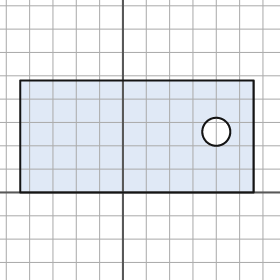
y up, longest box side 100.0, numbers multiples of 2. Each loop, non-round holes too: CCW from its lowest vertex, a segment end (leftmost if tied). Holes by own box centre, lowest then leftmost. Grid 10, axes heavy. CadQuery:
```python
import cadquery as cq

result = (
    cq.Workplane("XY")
    .moveTo(-44.0, 0.0)
    .lineTo(56.0, 0.0)
    .lineTo(56.0, 48.0)
    .lineTo(-44.0, 48.0)
    .close()
    .moveTo(40.0, 26.0)
    .circle(6.0)
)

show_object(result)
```